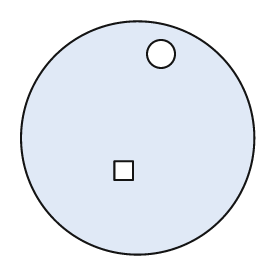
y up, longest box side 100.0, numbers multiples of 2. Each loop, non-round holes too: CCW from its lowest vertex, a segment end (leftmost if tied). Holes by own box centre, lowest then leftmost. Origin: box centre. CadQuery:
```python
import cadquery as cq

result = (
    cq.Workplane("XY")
    .moveTo(0.0, 0.0)
    .circle(50.0)
    .moveTo(-10.0, -18.0)
    .lineTo(-2.0, -18.0)
    .lineTo(-2.0, -10.0)
    .lineTo(-10.0, -10.0)
    .close()
    .moveTo(10.0, 36.0)
    .circle(6.0)
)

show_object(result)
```